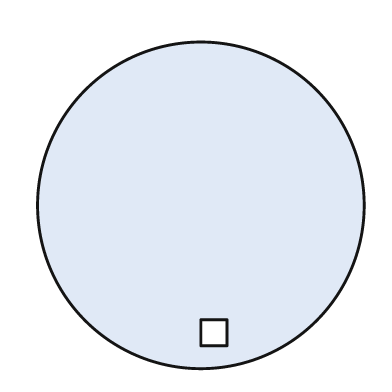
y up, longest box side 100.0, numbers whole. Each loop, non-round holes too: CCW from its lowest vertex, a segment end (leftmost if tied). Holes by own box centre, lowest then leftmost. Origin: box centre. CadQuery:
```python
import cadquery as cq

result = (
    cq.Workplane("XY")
    .moveTo(0.0, 0.0)
    .circle(50.0)
    .moveTo(0.0, -43.0)
    .lineTo(8.0, -43.0)
    .lineTo(8.0, -35.0)
    .lineTo(0.0, -35.0)
    .close()
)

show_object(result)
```